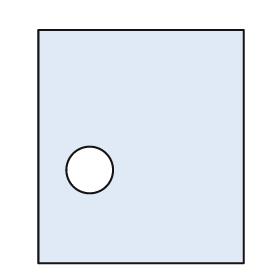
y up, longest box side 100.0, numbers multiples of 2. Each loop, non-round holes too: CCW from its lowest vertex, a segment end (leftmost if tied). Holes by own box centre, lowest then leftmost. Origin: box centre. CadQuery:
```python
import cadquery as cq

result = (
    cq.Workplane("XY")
    .moveTo(-44.0, -50.0)
    .lineTo(44.0, -50.0)
    .lineTo(44.0, 50.0)
    .lineTo(-44.0, 50.0)
    .close()
    .moveTo(-22.0, -10.0)
    .circle(10.0)
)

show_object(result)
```